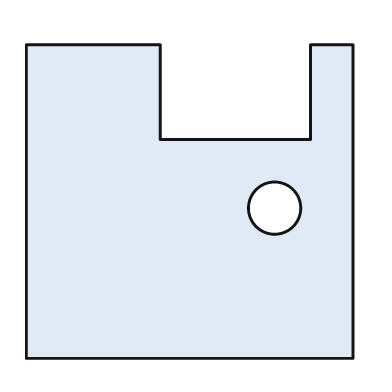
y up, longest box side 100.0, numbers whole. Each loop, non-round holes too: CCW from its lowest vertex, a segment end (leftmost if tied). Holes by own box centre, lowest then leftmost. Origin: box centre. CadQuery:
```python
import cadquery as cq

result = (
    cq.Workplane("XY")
    .moveTo(-50.0, -48.0)
    .lineTo(50.0, -48.0)
    .lineTo(50.0, 48.0)
    .lineTo(37.0, 48.0)
    .lineTo(37.0, 19.0)
    .lineTo(-9.0, 19.0)
    .lineTo(-9.0, 48.0)
    .lineTo(-50.0, 48.0)
    .close()
    .moveTo(26.0, -2.0)
    .circle(8.0)
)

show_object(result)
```